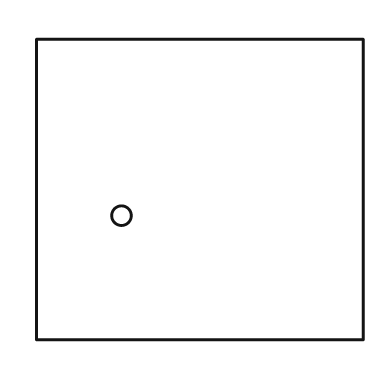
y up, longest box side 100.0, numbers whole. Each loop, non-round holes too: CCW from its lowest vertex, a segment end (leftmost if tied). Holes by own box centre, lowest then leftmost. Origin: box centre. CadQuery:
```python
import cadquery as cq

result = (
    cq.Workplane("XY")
    .moveTo(-50.0, -46.0)
    .lineTo(50.0, -46.0)
    .lineTo(50.0, 46.0)
    .lineTo(-50.0, 46.0)
    .close()
    .moveTo(-24.0, -8.0)
    .circle(3.0)
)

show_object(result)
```